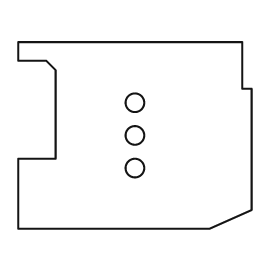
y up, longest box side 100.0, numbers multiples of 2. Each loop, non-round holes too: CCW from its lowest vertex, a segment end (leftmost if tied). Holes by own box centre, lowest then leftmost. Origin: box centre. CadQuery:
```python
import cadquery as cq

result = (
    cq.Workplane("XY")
    .moveTo(-50.0, -40.0)
    .lineTo(32.0, -40.0)
    .lineTo(50.0, -32.0)
    .lineTo(50.0, 20.0)
    .lineTo(46.0, 20.0)
    .lineTo(46.0, 40.0)
    .lineTo(-50.0, 40.0)
    .lineTo(-50.0, 32.0)
    .lineTo(-38.0, 32.0)
    .lineTo(-34.0, 28.0)
    .lineTo(-34.0, -10.0)
    .lineTo(-50.0, -10.0)
    .close()
    .moveTo(0.0, -14.0)
    .circle(4.0)
    .moveTo(0.0, 0.0)
    .circle(4.0)
    .moveTo(0.0, 14.0)
    .circle(4.0)
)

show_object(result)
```